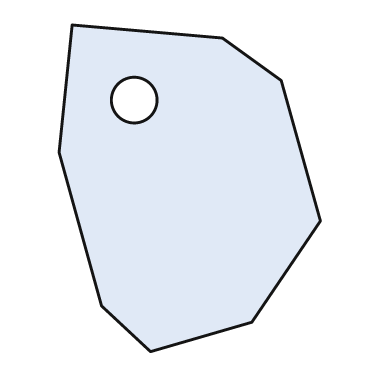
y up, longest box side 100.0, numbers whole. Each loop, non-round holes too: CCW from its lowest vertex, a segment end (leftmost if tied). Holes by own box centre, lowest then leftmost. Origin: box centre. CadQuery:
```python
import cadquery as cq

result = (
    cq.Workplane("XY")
    .moveTo(-12.0, -50.0)
    .lineTo(19.0, -41.0)
    .lineTo(40.0, -10.0)
    .lineTo(28.0, 33.0)
    .lineTo(10.0, 46.0)
    .lineTo(-36.0, 50.0)
    .lineTo(-40.0, 11.0)
    .lineTo(-27.0, -36.0)
    .close()
    .moveTo(-17.0, 27.0)
    .circle(7.0)
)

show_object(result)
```